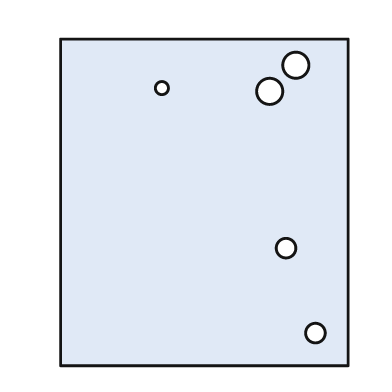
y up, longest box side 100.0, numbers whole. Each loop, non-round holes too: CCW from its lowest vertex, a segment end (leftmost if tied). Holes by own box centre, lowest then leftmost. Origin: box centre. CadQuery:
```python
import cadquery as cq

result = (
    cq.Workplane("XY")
    .moveTo(-44.0, -50.0)
    .lineTo(44.0, -50.0)
    .lineTo(44.0, 50.0)
    .lineTo(-44.0, 50.0)
    .close()
    .moveTo(34.0, -40.0)
    .circle(3.0)
    .moveTo(25.0, -14.0)
    .circle(3.0)
    .moveTo(20.0, 34.0)
    .circle(4.0)
    .moveTo(-13.0, 35.0)
    .circle(2.0)
    .moveTo(28.0, 42.0)
    .circle(4.0)
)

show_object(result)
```